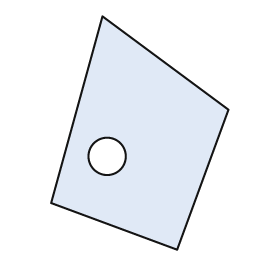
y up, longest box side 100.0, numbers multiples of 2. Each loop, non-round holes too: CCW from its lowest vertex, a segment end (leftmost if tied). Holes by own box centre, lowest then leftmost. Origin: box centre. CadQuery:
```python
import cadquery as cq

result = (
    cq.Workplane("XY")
    .moveTo(16.0, -50.0)
    .lineTo(38.0, 10.0)
    .lineTo(-16.0, 50.0)
    .lineTo(-38.0, -30.0)
    .close()
    .moveTo(-14.0, -10.0)
    .circle(8.0)
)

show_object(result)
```